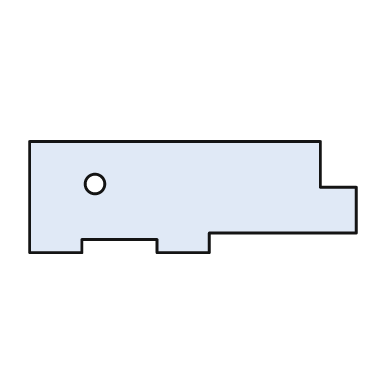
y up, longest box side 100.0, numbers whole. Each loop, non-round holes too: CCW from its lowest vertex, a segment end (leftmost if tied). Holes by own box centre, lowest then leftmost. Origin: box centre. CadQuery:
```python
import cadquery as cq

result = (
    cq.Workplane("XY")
    .moveTo(-50.0, -17.0)
    .lineTo(-34.0, -17.0)
    .lineTo(-34.0, -13.0)
    .lineTo(-11.0, -13.0)
    .lineTo(-11.0, -17.0)
    .lineTo(5.0, -17.0)
    .lineTo(5.0, -11.0)
    .lineTo(50.0, -11.0)
    .lineTo(50.0, 3.0)
    .lineTo(39.0, 3.0)
    .lineTo(39.0, 17.0)
    .lineTo(-50.0, 17.0)
    .close()
    .moveTo(-30.0, 4.0)
    .circle(3.0)
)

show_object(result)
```